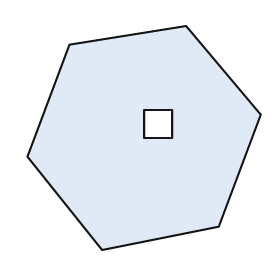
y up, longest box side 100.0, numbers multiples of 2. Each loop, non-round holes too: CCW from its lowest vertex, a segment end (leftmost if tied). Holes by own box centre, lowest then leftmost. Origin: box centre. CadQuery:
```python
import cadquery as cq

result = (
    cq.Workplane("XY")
    .moveTo(-18.0, -48.0)
    .lineTo(32.0, -38.0)
    .lineTo(50.0, 10.0)
    .lineTo(18.0, 48.0)
    .lineTo(-32.0, 40.0)
    .lineTo(-50.0, -8.0)
    .close()
    .moveTo(0.0, 0.0)
    .lineTo(12.0, 0.0)
    .lineTo(12.0, 12.0)
    .lineTo(0.0, 12.0)
    .close()
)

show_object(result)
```